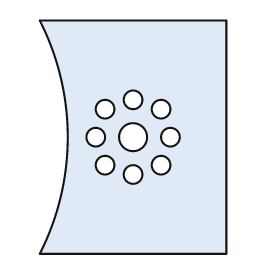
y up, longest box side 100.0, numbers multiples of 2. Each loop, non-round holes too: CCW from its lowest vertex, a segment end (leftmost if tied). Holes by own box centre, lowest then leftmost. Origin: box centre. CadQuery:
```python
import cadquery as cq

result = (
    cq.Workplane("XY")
    .moveTo(-40.0, -50.0)
    .lineTo(40.0, -50.0)
    .lineTo(40.0, 50.0)
    .lineTo(-40.0, 50.0)
    .threePointArc((-28.0, 0.0), (-40.0, -50.0))
    .close()
    .moveTo(0.0, -16.0)
    .circle(4.0)
    .moveTo(-12.0, -12.0)
    .circle(4.0)
    .moveTo(12.0, -12.0)
    .circle(4.0)
    .moveTo(-16.0, 0.0)
    .circle(4.0)
    .moveTo(0.0, 0.0)
    .circle(6.0)
    .moveTo(16.0, 0.0)
    .circle(4.0)
    .moveTo(-12.0, 12.0)
    .circle(4.0)
    .moveTo(12.0, 12.0)
    .circle(4.0)
    .moveTo(0.0, 16.0)
    .circle(4.0)
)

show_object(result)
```